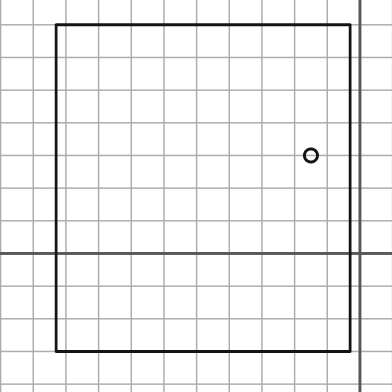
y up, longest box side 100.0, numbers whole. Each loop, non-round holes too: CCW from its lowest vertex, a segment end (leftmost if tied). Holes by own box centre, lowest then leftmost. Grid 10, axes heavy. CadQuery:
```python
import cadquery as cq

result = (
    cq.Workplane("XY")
    .moveTo(-93.0, -30.0)
    .lineTo(-3.0, -30.0)
    .lineTo(-3.0, 70.0)
    .lineTo(-93.0, 70.0)
    .close()
    .moveTo(-15.0, 30.0)
    .circle(2.0)
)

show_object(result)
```